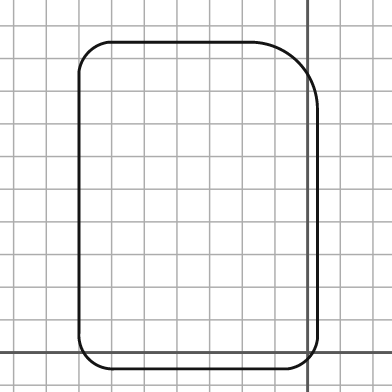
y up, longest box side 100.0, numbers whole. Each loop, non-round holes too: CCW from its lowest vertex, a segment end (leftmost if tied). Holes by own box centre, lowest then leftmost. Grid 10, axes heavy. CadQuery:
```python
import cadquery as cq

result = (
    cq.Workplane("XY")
    .moveTo(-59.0, -5.0)
    .lineTo(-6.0, -5.0)
    .threePointArc((0.0, -2.0), (3.0, 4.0))
    .lineTo(3.0, 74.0)
    .threePointArc((-3.0, 89.0), (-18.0, 95.0))
    .lineTo(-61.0, 95.0)
    .threePointArc((-67.0, 92.0), (-70.0, 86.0))
    .lineTo(-70.0, 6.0)
    .threePointArc((-67.0, -2.0), (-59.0, -5.0))
    .close()
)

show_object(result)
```